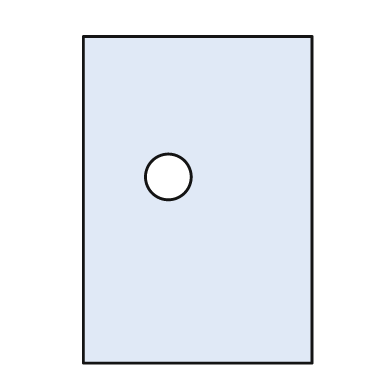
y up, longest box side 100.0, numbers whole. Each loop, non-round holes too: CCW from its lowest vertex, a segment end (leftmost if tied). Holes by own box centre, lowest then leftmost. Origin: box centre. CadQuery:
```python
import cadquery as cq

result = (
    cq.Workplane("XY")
    .moveTo(-35.0, -50.0)
    .lineTo(35.0, -50.0)
    .lineTo(35.0, 50.0)
    .lineTo(-35.0, 50.0)
    .close()
    .moveTo(-9.0, 7.0)
    .circle(7.0)
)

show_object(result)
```